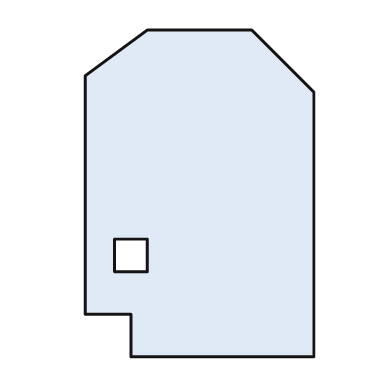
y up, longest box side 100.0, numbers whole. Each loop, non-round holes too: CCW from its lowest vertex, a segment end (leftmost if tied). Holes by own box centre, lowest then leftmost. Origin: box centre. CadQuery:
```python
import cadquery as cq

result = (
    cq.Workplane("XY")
    .moveTo(-21.0, -50.0)
    .lineTo(35.0, -50.0)
    .lineTo(35.0, 31.0)
    .lineTo(16.0, 50.0)
    .lineTo(-16.0, 50.0)
    .lineTo(-35.0, 36.0)
    .lineTo(-35.0, -37.0)
    .lineTo(-21.0, -37.0)
    .close()
    .moveTo(-26.0, -24.0)
    .lineTo(-16.0, -24.0)
    .lineTo(-16.0, -14.0)
    .lineTo(-26.0, -14.0)
    .close()
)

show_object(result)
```